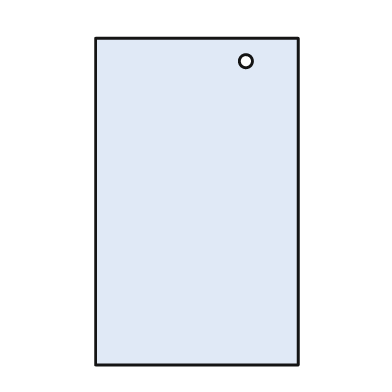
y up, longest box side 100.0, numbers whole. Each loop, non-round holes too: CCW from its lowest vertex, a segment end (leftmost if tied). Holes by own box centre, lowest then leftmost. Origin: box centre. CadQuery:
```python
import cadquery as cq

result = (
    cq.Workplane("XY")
    .moveTo(-31.0, -50.0)
    .lineTo(31.0, -50.0)
    .lineTo(31.0, 50.0)
    .lineTo(-31.0, 50.0)
    .close()
    .moveTo(15.0, 43.0)
    .circle(2.0)
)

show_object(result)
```